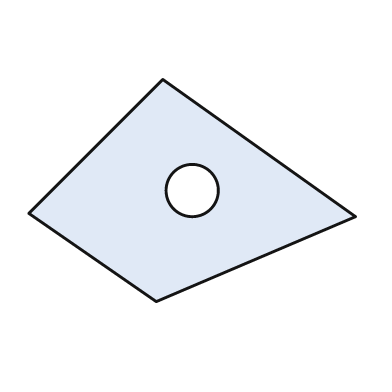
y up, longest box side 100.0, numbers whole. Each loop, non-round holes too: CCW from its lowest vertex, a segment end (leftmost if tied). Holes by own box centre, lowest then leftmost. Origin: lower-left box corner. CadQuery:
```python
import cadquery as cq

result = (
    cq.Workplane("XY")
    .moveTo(39.0, 0.0)
    .lineTo(100.0, 26.0)
    .lineTo(41.0, 68.0)
    .lineTo(0.0, 27.0)
    .close()
    .moveTo(50.0, 34.0)
    .circle(8.0)
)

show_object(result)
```